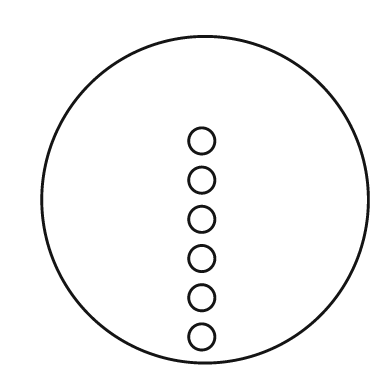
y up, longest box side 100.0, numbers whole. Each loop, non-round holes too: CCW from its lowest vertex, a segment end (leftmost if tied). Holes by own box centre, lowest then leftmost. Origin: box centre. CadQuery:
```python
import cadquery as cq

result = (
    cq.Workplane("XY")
    .moveTo(0.0, 0.0)
    .circle(50.0)
    .moveTo(-1.0, -42.0)
    .circle(4.0)
    .moveTo(-1.0, -30.0)
    .circle(4.0)
    .moveTo(-1.0, -18.0)
    .circle(4.0)
    .moveTo(-1.0, -6.0)
    .circle(4.0)
    .moveTo(-1.0, 6.0)
    .circle(4.0)
    .moveTo(-1.0, 18.0)
    .circle(4.0)
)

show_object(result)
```